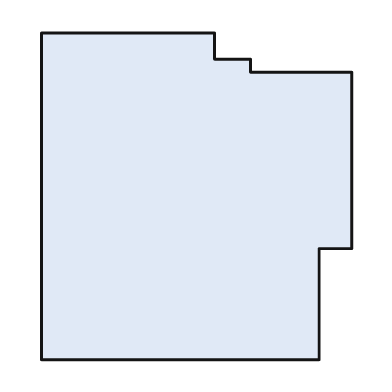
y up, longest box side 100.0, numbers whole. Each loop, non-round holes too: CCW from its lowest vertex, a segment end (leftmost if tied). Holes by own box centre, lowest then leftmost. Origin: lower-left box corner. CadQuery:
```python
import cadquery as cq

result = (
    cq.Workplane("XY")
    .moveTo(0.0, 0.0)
    .lineTo(85.0, 0.0)
    .lineTo(85.0, 34.0)
    .lineTo(95.0, 34.0)
    .lineTo(95.0, 88.0)
    .lineTo(64.0, 88.0)
    .lineTo(64.0, 92.0)
    .lineTo(53.0, 92.0)
    .lineTo(53.0, 100.0)
    .lineTo(0.0, 100.0)
    .close()
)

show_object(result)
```